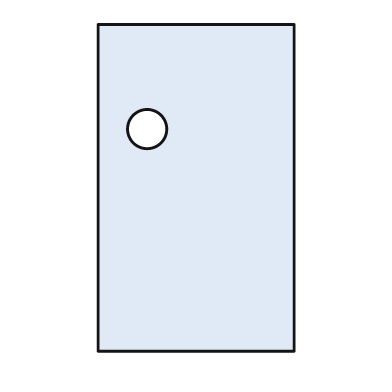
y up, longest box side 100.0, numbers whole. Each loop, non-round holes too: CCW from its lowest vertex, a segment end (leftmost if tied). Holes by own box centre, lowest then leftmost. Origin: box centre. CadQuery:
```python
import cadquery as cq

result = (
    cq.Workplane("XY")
    .moveTo(-30.0, -50.0)
    .lineTo(30.0, -50.0)
    .lineTo(30.0, 50.0)
    .lineTo(-30.0, 50.0)
    .close()
    .moveTo(-15.0, 18.0)
    .circle(6.0)
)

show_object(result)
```